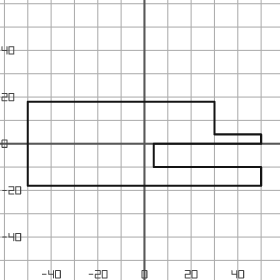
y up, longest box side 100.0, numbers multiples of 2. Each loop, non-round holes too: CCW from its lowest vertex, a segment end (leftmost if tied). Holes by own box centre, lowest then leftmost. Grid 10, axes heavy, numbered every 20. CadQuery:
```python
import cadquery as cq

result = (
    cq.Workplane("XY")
    .moveTo(-50.0, -18.0)
    .lineTo(50.0, -18.0)
    .lineTo(50.0, -10.0)
    .lineTo(4.0, -10.0)
    .lineTo(4.0, 0.0)
    .lineTo(50.0, 0.0)
    .lineTo(50.0, 4.0)
    .lineTo(30.0, 4.0)
    .lineTo(30.0, 18.0)
    .lineTo(-50.0, 18.0)
    .close()
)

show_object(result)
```